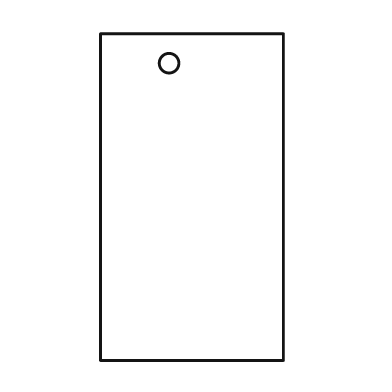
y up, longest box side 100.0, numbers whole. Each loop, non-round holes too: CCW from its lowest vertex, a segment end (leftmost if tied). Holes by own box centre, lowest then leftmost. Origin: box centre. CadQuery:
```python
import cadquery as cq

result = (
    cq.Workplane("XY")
    .moveTo(-28.0, -50.0)
    .lineTo(28.0, -50.0)
    .lineTo(28.0, 50.0)
    .lineTo(-28.0, 50.0)
    .close()
    .moveTo(-7.0, 41.0)
    .circle(3.0)
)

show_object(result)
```